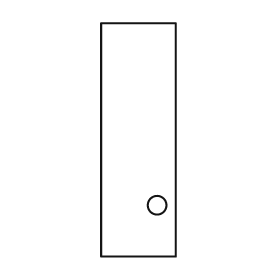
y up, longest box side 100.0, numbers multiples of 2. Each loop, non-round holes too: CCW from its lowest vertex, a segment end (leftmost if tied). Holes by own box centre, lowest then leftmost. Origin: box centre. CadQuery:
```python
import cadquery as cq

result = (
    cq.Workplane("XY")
    .moveTo(-16.0, -50.0)
    .lineTo(16.0, -50.0)
    .lineTo(16.0, 50.0)
    .lineTo(-16.0, 50.0)
    .close()
    .moveTo(8.0, -28.0)
    .circle(4.0)
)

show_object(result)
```